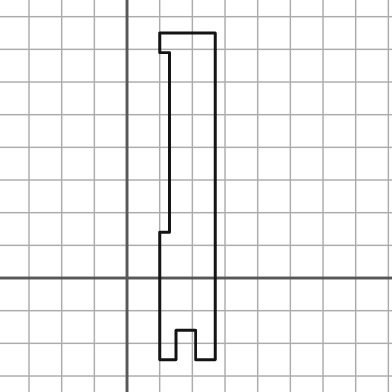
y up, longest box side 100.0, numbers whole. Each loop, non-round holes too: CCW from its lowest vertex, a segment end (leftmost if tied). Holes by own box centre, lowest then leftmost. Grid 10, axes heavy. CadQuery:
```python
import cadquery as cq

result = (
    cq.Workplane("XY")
    .moveTo(10.0, -25.0)
    .lineTo(15.0, -25.0)
    .lineTo(15.0, -16.0)
    .lineTo(21.0, -16.0)
    .lineTo(21.0, -25.0)
    .lineTo(27.0, -25.0)
    .lineTo(27.0, 75.0)
    .lineTo(10.0, 75.0)
    .lineTo(10.0, 69.0)
    .lineTo(13.0, 69.0)
    .lineTo(13.0, 14.0)
    .lineTo(10.0, 14.0)
    .close()
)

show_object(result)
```